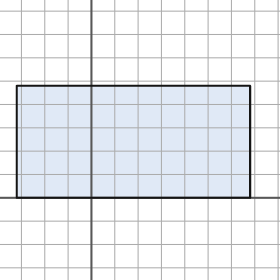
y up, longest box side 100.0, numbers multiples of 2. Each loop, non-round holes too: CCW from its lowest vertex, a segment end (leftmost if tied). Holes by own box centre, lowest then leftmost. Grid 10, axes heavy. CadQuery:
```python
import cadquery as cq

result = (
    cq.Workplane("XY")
    .moveTo(-32.0, 0.0)
    .lineTo(68.0, 0.0)
    .lineTo(68.0, 48.0)
    .lineTo(-32.0, 48.0)
    .close()
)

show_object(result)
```